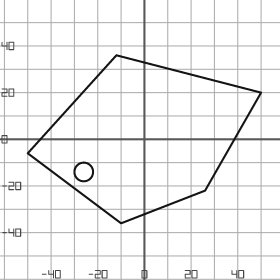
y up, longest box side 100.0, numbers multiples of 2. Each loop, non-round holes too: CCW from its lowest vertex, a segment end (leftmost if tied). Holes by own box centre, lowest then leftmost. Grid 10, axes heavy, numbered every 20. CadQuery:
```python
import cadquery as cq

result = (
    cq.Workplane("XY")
    .moveTo(-10.0, -36.0)
    .lineTo(26.0, -22.0)
    .lineTo(50.0, 20.0)
    .lineTo(-12.0, 36.0)
    .lineTo(-50.0, -6.0)
    .close()
    .moveTo(-26.0, -14.0)
    .circle(4.0)
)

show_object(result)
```